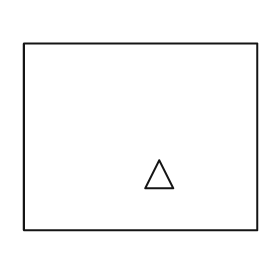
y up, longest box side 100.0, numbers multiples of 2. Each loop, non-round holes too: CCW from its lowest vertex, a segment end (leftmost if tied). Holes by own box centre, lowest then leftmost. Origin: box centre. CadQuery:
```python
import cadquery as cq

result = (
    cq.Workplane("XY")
    .moveTo(-50.0, -40.0)
    .lineTo(50.0, -40.0)
    .lineTo(50.0, 40.0)
    .lineTo(-50.0, 40.0)
    .close()
    .moveTo(2.0, -22.0)
    .lineTo(14.0, -22.0)
    .lineTo(8.0, -10.0)
    .close()
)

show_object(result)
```